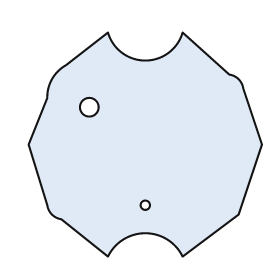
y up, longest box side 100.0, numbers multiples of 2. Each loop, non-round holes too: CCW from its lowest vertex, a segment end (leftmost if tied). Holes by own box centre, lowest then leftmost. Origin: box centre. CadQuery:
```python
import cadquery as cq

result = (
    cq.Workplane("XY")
    .moveTo(-16.0, -48.0)
    .threePointArc((0.0, -38.0), (16.0, -48.0))
    .lineTo(40.0, -30.0)
    .lineTo(50.0, 0.0)
    .lineTo(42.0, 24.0)
    .threePointArc((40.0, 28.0), (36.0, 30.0))
    .lineTo(16.0, 48.0)
    .threePointArc((0.0, 36.0), (-16.0, 48.0))
    .lineTo(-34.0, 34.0)
    .threePointArc((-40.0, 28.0), (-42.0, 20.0))
    .lineTo(-50.0, 0.0)
    .lineTo(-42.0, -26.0)
    .threePointArc((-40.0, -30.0), (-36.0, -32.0))
    .close()
    .moveTo(0.0, -26.0)
    .circle(2.0)
    .moveTo(-24.0, 16.0)
    .circle(4.0)
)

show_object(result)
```